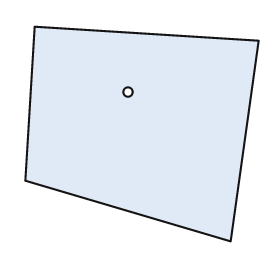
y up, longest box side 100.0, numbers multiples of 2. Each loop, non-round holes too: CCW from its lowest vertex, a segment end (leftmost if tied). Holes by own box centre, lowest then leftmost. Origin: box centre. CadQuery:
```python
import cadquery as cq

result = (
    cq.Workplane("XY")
    .moveTo(38.0, -46.0)
    .lineTo(50.0, 40.0)
    .lineTo(-46.0, 46.0)
    .lineTo(-50.0, -20.0)
    .close()
    .moveTo(-6.0, 18.0)
    .circle(2.0)
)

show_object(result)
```